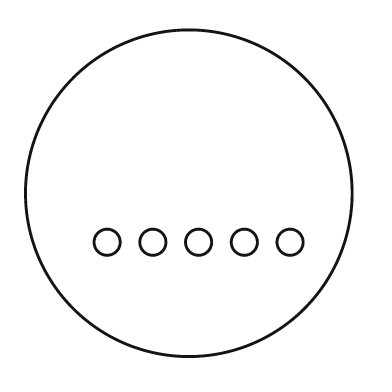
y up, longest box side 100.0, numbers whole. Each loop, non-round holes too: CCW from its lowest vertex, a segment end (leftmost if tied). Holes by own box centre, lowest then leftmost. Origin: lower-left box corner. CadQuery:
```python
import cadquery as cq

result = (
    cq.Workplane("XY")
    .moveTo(50.0, 50.0)
    .circle(50.0)
    .moveTo(25.0, 35.0)
    .circle(4.0)
    .moveTo(39.0, 35.0)
    .circle(4.0)
    .moveTo(53.0, 35.0)
    .circle(4.0)
    .moveTo(67.0, 35.0)
    .circle(4.0)
    .moveTo(81.0, 35.0)
    .circle(4.0)
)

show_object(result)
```